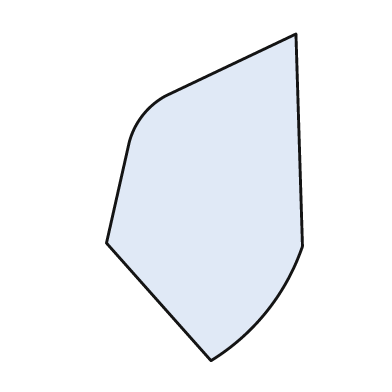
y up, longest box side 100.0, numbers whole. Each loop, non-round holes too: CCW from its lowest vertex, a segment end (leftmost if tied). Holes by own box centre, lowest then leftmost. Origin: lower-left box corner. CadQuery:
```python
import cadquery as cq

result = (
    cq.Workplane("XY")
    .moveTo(32.0, 0.0)
    .threePointArc((49.0, 15.0), (60.0, 35.0))
    .lineTo(58.0, 100.0)
    .lineTo(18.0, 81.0)
    .threePointArc((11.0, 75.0), (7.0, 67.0))
    .lineTo(0.0, 36.0)
    .close()
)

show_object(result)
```